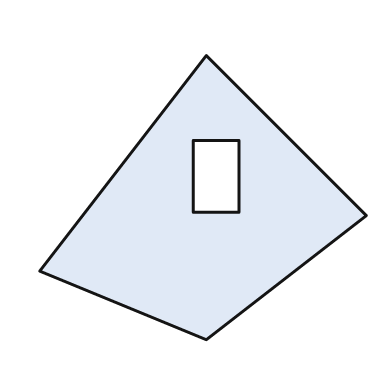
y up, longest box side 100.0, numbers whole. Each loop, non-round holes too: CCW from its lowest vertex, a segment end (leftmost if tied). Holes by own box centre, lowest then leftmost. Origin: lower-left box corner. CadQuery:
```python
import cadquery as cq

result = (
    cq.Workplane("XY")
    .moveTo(51.0, 0.0)
    .lineTo(100.0, 38.0)
    .lineTo(51.0, 87.0)
    .lineTo(0.0, 21.0)
    .close()
    .moveTo(47.0, 39.0)
    .lineTo(61.0, 39.0)
    .lineTo(61.0, 61.0)
    .lineTo(47.0, 61.0)
    .close()
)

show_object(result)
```